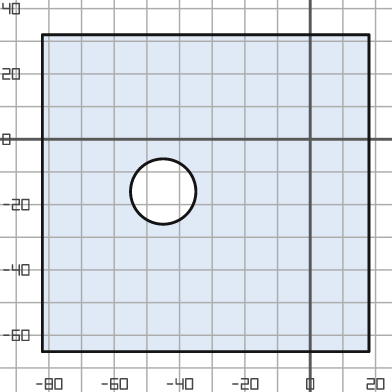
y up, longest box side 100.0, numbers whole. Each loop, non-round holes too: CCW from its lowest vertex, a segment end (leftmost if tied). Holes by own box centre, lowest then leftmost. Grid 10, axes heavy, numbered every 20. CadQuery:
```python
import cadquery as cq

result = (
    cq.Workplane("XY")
    .moveTo(-82.0, -65.0)
    .lineTo(18.0, -65.0)
    .lineTo(18.0, 32.0)
    .lineTo(-82.0, 32.0)
    .close()
    .moveTo(-45.0, -16.0)
    .circle(10.0)
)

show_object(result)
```